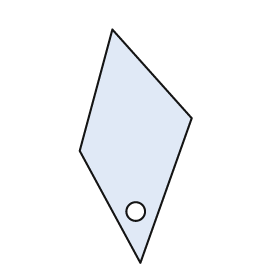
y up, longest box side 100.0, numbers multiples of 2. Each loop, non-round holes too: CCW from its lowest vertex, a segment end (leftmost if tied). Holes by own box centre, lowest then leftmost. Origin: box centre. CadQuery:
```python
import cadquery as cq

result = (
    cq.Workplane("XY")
    .moveTo(2.0, -50.0)
    .lineTo(24.0, 12.0)
    .lineTo(-10.0, 50.0)
    .lineTo(-24.0, -2.0)
    .close()
    .moveTo(0.0, -28.0)
    .circle(4.0)
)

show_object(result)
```